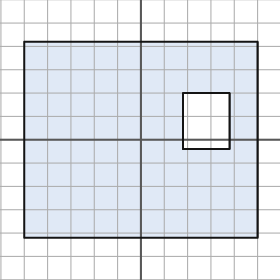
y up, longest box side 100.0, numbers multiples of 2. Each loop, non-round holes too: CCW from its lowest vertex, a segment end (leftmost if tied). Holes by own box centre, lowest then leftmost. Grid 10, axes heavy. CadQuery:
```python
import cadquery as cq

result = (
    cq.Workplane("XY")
    .moveTo(-50.0, -42.0)
    .lineTo(50.0, -42.0)
    .lineTo(50.0, 42.0)
    .lineTo(-50.0, 42.0)
    .close()
    .moveTo(18.0, -4.0)
    .lineTo(38.0, -4.0)
    .lineTo(38.0, 20.0)
    .lineTo(18.0, 20.0)
    .close()
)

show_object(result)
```